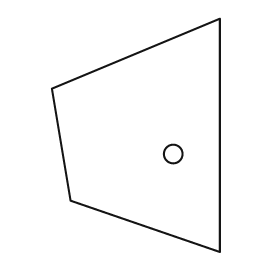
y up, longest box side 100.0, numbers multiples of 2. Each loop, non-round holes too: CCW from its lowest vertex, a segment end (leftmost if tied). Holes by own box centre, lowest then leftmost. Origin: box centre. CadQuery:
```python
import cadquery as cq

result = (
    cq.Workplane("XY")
    .moveTo(36.0, -50.0)
    .lineTo(36.0, 50.0)
    .lineTo(-36.0, 20.0)
    .lineTo(-28.0, -28.0)
    .close()
    .moveTo(16.0, -8.0)
    .circle(4.0)
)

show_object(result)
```